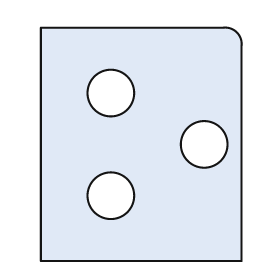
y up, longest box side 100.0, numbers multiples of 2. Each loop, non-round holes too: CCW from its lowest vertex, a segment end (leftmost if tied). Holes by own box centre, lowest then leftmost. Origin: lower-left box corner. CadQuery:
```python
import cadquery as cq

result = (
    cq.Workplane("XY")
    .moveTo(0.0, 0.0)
    .lineTo(86.0, 0.0)
    .lineTo(86.0, 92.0)
    .threePointArc((84.0, 98.0), (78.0, 100.0))
    .lineTo(0.0, 100.0)
    .close()
    .moveTo(30.0, 28.0)
    .circle(10.0)
    .moveTo(70.0, 50.0)
    .circle(10.0)
    .moveTo(30.0, 72.0)
    .circle(10.0)
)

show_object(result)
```